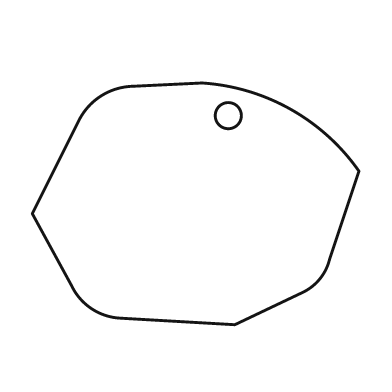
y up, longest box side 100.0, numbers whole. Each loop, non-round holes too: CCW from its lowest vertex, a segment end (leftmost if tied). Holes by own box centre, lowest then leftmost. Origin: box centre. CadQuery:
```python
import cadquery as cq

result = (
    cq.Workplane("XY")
    .moveTo(12.0, -37.0)
    .lineTo(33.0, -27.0)
    .threePointArc((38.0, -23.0), (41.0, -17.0))
    .lineTo(50.0, 10.0)
    .threePointArc((29.0, 29.0), (2.0, 37.0))
    .lineTo(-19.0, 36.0)
    .threePointArc((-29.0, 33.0), (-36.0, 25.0))
    .lineTo(-50.0, -3.0)
    .lineTo(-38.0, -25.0)
    .threePointArc((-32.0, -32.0), (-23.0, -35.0))
    .close()
    .moveTo(10.0, 27.0)
    .circle(4.0)
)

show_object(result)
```